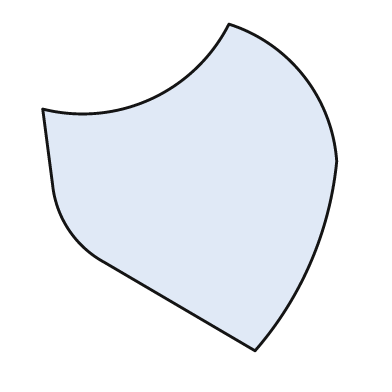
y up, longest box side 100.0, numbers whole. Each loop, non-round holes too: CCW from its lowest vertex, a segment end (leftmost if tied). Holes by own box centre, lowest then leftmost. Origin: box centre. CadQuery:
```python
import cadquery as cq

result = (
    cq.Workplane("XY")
    .moveTo(20.0, -50.0)
    .threePointArc((37.0, -23.0), (45.0, 8.0))
    .threePointArc((35.0, 34.0), (12.0, 50.0))
    .threePointArc((-12.0, 27.0), (-45.0, 24.0))
    .lineTo(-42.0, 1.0)
    .threePointArc((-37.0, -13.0), (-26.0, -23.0))
    .close()
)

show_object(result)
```